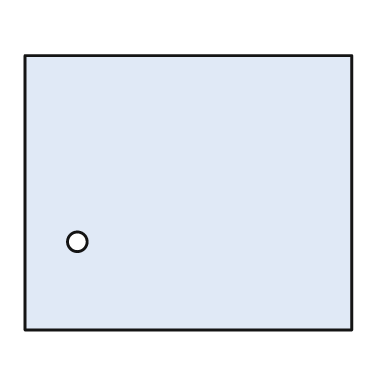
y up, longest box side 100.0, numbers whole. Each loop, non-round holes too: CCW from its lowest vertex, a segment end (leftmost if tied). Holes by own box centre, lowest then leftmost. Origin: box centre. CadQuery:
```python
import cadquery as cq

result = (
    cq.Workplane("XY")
    .moveTo(-50.0, -42.0)
    .lineTo(50.0, -42.0)
    .lineTo(50.0, 42.0)
    .lineTo(-50.0, 42.0)
    .close()
    .moveTo(-34.0, -15.0)
    .circle(3.0)
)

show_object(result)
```